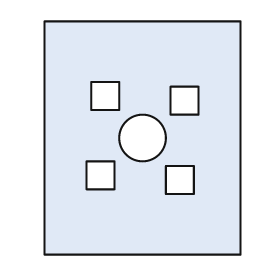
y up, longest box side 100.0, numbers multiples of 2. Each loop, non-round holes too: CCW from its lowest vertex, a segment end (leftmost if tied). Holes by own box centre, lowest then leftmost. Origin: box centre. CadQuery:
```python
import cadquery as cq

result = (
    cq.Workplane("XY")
    .moveTo(-42.0, -50.0)
    .lineTo(42.0, -50.0)
    .lineTo(42.0, 50.0)
    .lineTo(-42.0, 50.0)
    .close()
    .moveTo(10.0, -24.0)
    .lineTo(22.0, -24.0)
    .lineTo(22.0, -12.0)
    .lineTo(10.0, -12.0)
    .close()
    .moveTo(-24.0, -22.0)
    .lineTo(-12.0, -22.0)
    .lineTo(-12.0, -10.0)
    .lineTo(-24.0, -10.0)
    .close()
    .moveTo(0.0, 0.0)
    .circle(10.0)
    .moveTo(12.0, 10.0)
    .lineTo(24.0, 10.0)
    .lineTo(24.0, 22.0)
    .lineTo(12.0, 22.0)
    .close()
    .moveTo(-22.0, 12.0)
    .lineTo(-10.0, 12.0)
    .lineTo(-10.0, 24.0)
    .lineTo(-22.0, 24.0)
    .close()
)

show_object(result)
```